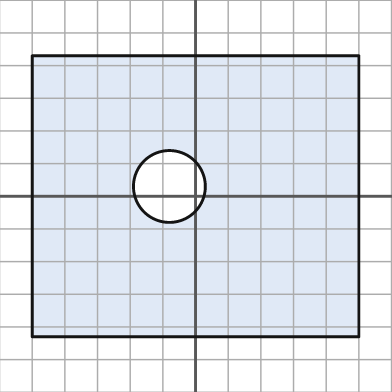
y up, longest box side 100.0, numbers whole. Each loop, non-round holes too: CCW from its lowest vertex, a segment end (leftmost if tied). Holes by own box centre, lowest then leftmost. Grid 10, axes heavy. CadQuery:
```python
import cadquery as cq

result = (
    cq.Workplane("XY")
    .moveTo(-50.0, -43.0)
    .lineTo(50.0, -43.0)
    .lineTo(50.0, 43.0)
    .lineTo(-50.0, 43.0)
    .close()
    .moveTo(-8.0, 3.0)
    .circle(11.0)
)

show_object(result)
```